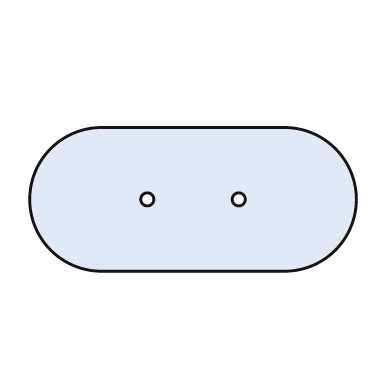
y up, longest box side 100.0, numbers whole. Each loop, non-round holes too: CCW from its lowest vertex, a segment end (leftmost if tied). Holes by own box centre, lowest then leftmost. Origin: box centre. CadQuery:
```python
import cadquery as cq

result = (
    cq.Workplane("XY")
    .moveTo(-28.0, -22.0)
    .lineTo(28.0, -22.0)
    .threePointArc((50.0, 0.0), (28.0, 22.0))
    .lineTo(-28.0, 22.0)
    .threePointArc((-50.0, 0.0), (-28.0, -22.0))
    .close()
    .moveTo(-14.0, 0.0)
    .circle(2.0)
    .moveTo(14.0, 0.0)
    .circle(2.0)
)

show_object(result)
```